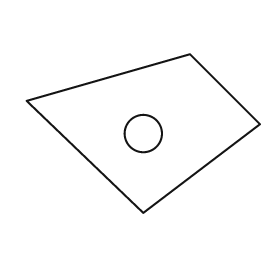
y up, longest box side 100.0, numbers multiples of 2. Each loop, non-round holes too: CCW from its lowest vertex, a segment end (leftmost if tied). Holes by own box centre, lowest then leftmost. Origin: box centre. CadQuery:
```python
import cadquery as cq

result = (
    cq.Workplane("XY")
    .moveTo(0.0, -34.0)
    .lineTo(50.0, 4.0)
    .lineTo(20.0, 34.0)
    .lineTo(-50.0, 14.0)
    .close()
    .moveTo(0.0, 0.0)
    .circle(8.0)
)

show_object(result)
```